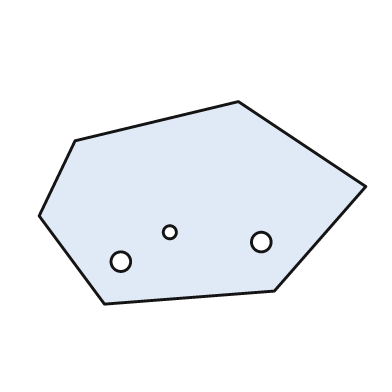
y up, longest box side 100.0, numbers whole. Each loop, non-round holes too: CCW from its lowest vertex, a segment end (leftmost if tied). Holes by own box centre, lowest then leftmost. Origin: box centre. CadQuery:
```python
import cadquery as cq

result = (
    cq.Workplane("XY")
    .moveTo(-30.0, -31.0)
    .lineTo(22.0, -27.0)
    .lineTo(50.0, 5.0)
    .lineTo(11.0, 31.0)
    .lineTo(-39.0, 19.0)
    .lineTo(-50.0, -4.0)
    .close()
    .moveTo(-25.0, -18.0)
    .circle(3.0)
    .moveTo(18.0, -12.0)
    .circle(3.0)
    .moveTo(-10.0, -9.0)
    .circle(2.0)
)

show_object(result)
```